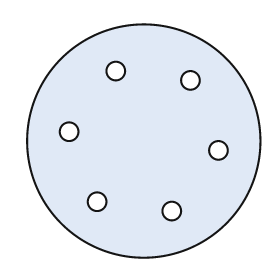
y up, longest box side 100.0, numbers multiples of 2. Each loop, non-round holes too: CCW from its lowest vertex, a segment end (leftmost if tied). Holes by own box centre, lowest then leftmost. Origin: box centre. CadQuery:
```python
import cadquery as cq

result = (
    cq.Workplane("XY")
    .moveTo(0.0, 0.0)
    .circle(50.0)
    .moveTo(12.0, -30.0)
    .circle(4.0)
    .moveTo(-20.0, -26.0)
    .circle(4.0)
    .moveTo(32.0, -4.0)
    .circle(4.0)
    .moveTo(-32.0, 4.0)
    .circle(4.0)
    .moveTo(20.0, 26.0)
    .circle(4.0)
    .moveTo(-12.0, 30.0)
    .circle(4.0)
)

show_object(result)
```